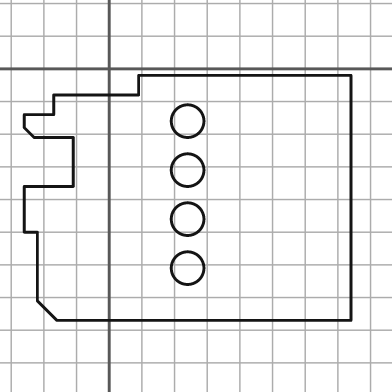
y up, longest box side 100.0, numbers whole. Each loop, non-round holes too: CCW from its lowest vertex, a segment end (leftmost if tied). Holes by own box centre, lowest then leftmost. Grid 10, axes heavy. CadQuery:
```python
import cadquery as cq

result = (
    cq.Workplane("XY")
    .moveTo(-16.0, -77.0)
    .lineTo(74.0, -77.0)
    .lineTo(74.0, -2.0)
    .lineTo(9.0, -2.0)
    .lineTo(9.0, -8.0)
    .lineTo(-17.0, -8.0)
    .lineTo(-17.0, -14.0)
    .lineTo(-26.0, -14.0)
    .lineTo(-26.0, -18.0)
    .lineTo(-23.0, -21.0)
    .lineTo(-11.0, -21.0)
    .lineTo(-11.0, -36.0)
    .lineTo(-26.0, -36.0)
    .lineTo(-26.0, -50.0)
    .lineTo(-22.0, -50.0)
    .lineTo(-22.0, -71.0)
    .close()
    .moveTo(24.0, -61.0)
    .circle(5.0)
    .moveTo(24.0, -46.0)
    .circle(5.0)
    .moveTo(24.0, -31.0)
    .circle(5.0)
    .moveTo(24.0, -16.0)
    .circle(5.0)
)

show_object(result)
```